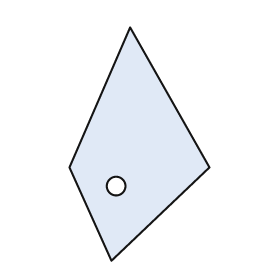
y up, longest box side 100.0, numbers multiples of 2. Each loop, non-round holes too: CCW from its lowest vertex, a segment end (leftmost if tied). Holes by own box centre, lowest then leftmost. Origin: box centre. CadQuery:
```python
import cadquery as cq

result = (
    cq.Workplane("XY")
    .moveTo(-12.0, -50.0)
    .lineTo(30.0, -10.0)
    .lineTo(-4.0, 50.0)
    .lineTo(-30.0, -10.0)
    .close()
    .moveTo(-10.0, -18.0)
    .circle(4.0)
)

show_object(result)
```